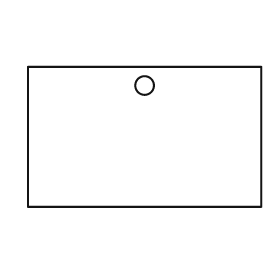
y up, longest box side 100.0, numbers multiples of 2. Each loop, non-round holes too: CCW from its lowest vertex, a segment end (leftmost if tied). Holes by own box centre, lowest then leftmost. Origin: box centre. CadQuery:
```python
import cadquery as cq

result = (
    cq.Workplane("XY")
    .moveTo(-50.0, -30.0)
    .lineTo(50.0, -30.0)
    .lineTo(50.0, 30.0)
    .lineTo(-50.0, 30.0)
    .close()
    .moveTo(0.0, 22.0)
    .circle(4.0)
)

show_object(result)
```